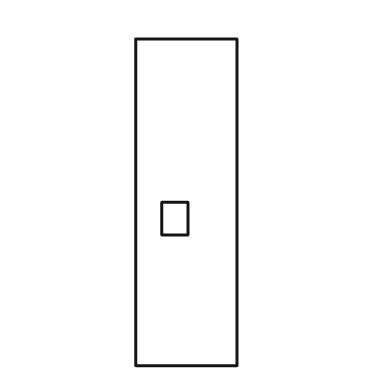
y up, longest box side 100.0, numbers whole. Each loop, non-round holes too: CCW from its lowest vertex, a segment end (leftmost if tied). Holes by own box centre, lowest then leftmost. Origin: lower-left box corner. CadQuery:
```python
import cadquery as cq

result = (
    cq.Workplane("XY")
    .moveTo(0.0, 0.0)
    .lineTo(31.0, 0.0)
    .lineTo(31.0, 100.0)
    .lineTo(0.0, 100.0)
    .close()
    .moveTo(8.0, 40.0)
    .lineTo(16.0, 40.0)
    .lineTo(16.0, 50.0)
    .lineTo(8.0, 50.0)
    .close()
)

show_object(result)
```